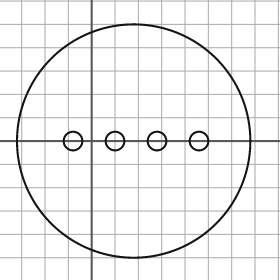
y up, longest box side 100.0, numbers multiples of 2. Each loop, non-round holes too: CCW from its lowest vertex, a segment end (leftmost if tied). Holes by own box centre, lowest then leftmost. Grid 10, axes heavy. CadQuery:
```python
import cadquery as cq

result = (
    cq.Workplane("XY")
    .moveTo(18.0, 0.0)
    .circle(50.0)
    .moveTo(-8.0, 0.0)
    .circle(4.0)
    .moveTo(10.0, 0.0)
    .circle(4.0)
    .moveTo(28.0, 0.0)
    .circle(4.0)
    .moveTo(46.0, 0.0)
    .circle(4.0)
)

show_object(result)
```